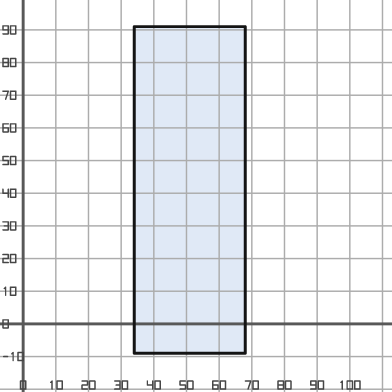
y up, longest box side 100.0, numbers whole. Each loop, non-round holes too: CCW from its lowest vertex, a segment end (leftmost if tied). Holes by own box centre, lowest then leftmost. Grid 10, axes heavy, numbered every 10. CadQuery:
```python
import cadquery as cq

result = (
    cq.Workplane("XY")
    .moveTo(34.0, -9.0)
    .lineTo(68.0, -9.0)
    .lineTo(68.0, 91.0)
    .lineTo(34.0, 91.0)
    .close()
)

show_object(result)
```